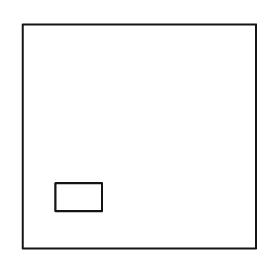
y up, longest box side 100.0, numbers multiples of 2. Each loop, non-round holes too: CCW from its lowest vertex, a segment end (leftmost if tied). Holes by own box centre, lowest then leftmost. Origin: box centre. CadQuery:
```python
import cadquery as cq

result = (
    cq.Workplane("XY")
    .moveTo(-50.0, -48.0)
    .lineTo(50.0, -48.0)
    .lineTo(50.0, 48.0)
    .lineTo(-50.0, 48.0)
    .close()
    .moveTo(-36.0, -32.0)
    .lineTo(-16.0, -32.0)
    .lineTo(-16.0, -20.0)
    .lineTo(-36.0, -20.0)
    .close()
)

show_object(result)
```